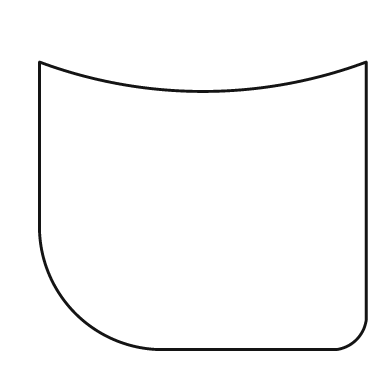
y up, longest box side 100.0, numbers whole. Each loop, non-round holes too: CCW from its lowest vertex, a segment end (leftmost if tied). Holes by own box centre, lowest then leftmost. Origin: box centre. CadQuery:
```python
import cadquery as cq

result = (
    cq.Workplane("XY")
    .moveTo(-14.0, -44.0)
    .lineTo(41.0, -44.0)
    .threePointArc((47.0, -41.0), (50.0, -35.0))
    .lineTo(50.0, 44.0)
    .threePointArc((0.0, 35.0), (-50.0, 44.0))
    .lineTo(-50.0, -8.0)
    .threePointArc((-39.0, -33.0), (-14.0, -44.0))
    .close()
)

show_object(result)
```